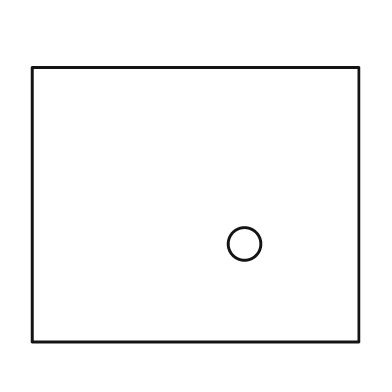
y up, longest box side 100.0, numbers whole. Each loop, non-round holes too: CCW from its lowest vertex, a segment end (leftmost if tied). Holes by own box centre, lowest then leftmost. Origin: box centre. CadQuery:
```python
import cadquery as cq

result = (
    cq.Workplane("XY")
    .moveTo(-50.0, -42.0)
    .lineTo(50.0, -42.0)
    .lineTo(50.0, 42.0)
    .lineTo(-50.0, 42.0)
    .close()
    .moveTo(15.0, -12.0)
    .circle(5.0)
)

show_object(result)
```